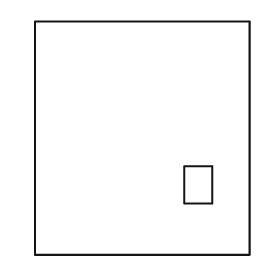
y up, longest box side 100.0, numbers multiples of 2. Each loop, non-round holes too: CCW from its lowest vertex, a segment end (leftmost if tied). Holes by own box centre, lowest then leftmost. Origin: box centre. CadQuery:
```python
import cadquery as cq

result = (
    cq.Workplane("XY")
    .moveTo(-46.0, -50.0)
    .lineTo(46.0, -50.0)
    .lineTo(46.0, 50.0)
    .lineTo(-46.0, 50.0)
    .close()
    .moveTo(18.0, -28.0)
    .lineTo(30.0, -28.0)
    .lineTo(30.0, -12.0)
    .lineTo(18.0, -12.0)
    .close()
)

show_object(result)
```